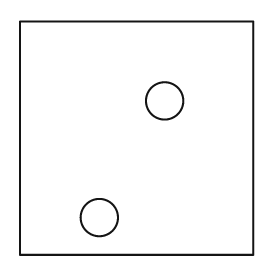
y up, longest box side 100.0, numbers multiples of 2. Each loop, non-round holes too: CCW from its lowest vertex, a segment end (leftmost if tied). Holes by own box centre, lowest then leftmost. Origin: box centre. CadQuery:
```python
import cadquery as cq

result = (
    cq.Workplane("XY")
    .moveTo(-50.0, -50.0)
    .lineTo(50.0, -50.0)
    .lineTo(50.0, 50.0)
    .lineTo(-50.0, 50.0)
    .close()
    .moveTo(-16.0, -34.0)
    .circle(8.0)
    .moveTo(12.0, 16.0)
    .circle(8.0)
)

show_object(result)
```